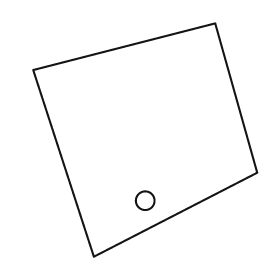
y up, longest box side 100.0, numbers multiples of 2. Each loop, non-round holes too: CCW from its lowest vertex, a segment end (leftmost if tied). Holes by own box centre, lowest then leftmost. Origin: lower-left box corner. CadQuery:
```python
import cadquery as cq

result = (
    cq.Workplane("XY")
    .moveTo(26.0, 0.0)
    .lineTo(96.0, 36.0)
    .lineTo(78.0, 100.0)
    .lineTo(0.0, 80.0)
    .close()
    .moveTo(48.0, 24.0)
    .circle(4.0)
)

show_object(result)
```